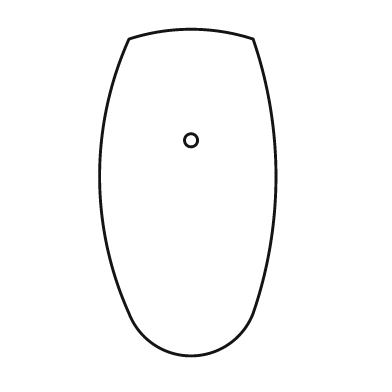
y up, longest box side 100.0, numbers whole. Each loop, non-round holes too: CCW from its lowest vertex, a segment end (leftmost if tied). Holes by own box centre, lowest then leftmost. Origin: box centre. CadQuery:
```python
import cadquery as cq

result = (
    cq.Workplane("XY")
    .moveTo(-18.0, -37.0)
    .threePointArc((1.0, -50.0), (20.0, -37.0))
    .threePointArc((27.0, 5.0), (20.0, 47.0))
    .threePointArc((1.0, 50.0), (-18.0, 47.0))
    .threePointArc((-27.0, 5.0), (-18.0, -37.0))
    .close()
    .moveTo(1.0, 16.0)
    .circle(2.0)
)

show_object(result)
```